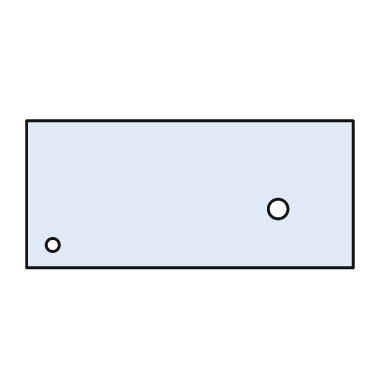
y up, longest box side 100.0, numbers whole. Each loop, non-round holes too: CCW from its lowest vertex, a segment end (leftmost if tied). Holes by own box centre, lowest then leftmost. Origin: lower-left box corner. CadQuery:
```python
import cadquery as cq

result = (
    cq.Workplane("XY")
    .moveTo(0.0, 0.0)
    .lineTo(100.0, 0.0)
    .lineTo(100.0, 45.0)
    .lineTo(0.0, 45.0)
    .close()
    .moveTo(8.0, 7.0)
    .circle(2.0)
    .moveTo(77.0, 18.0)
    .circle(3.0)
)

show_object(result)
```